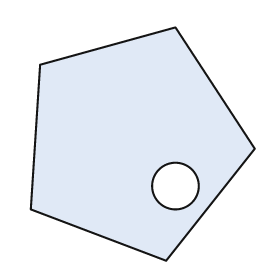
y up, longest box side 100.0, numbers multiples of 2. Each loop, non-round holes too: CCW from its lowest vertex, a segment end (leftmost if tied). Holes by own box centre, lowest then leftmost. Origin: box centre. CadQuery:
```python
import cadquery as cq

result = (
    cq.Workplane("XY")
    .moveTo(10.0, -50.0)
    .lineTo(48.0, -2.0)
    .lineTo(14.0, 50.0)
    .lineTo(-44.0, 34.0)
    .lineTo(-48.0, -28.0)
    .close()
    .moveTo(14.0, -18.0)
    .circle(10.0)
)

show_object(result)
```